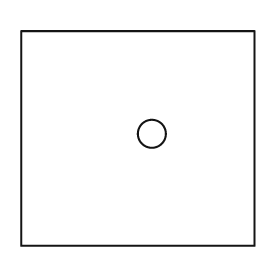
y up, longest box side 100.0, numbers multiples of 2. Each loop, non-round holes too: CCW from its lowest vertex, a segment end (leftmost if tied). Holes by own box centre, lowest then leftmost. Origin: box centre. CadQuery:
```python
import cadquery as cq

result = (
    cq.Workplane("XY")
    .moveTo(-50.0, -46.0)
    .lineTo(50.0, -46.0)
    .lineTo(50.0, 46.0)
    .lineTo(-50.0, 46.0)
    .close()
    .moveTo(6.0, 2.0)
    .circle(6.0)
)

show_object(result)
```